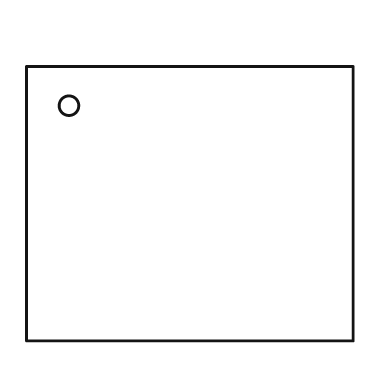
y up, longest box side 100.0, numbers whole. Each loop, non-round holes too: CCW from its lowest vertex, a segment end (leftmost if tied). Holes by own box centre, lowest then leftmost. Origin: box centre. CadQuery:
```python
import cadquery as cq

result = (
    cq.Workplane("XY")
    .moveTo(-50.0, -42.0)
    .lineTo(50.0, -42.0)
    .lineTo(50.0, 42.0)
    .lineTo(-50.0, 42.0)
    .close()
    .moveTo(-37.0, 30.0)
    .circle(3.0)
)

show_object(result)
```